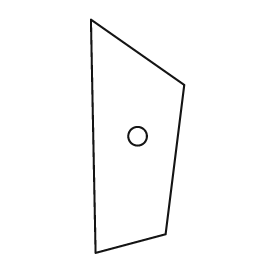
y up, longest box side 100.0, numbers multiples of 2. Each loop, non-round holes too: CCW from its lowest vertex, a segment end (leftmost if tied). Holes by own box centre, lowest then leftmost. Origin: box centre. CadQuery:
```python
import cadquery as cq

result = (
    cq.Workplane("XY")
    .moveTo(-18.0, -50.0)
    .lineTo(12.0, -42.0)
    .lineTo(20.0, 22.0)
    .lineTo(-20.0, 50.0)
    .close()
    .moveTo(0.0, 0.0)
    .circle(4.0)
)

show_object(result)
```